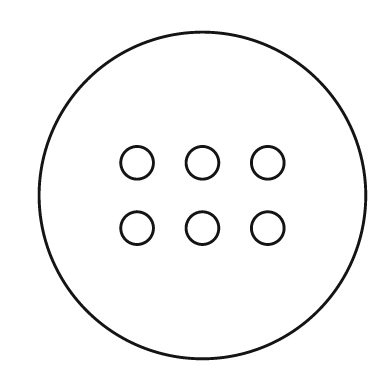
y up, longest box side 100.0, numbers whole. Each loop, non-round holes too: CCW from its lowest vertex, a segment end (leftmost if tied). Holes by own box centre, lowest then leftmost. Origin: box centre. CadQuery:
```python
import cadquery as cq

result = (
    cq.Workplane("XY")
    .moveTo(0.0, 0.0)
    .circle(50.0)
    .moveTo(-20.0, -10.0)
    .circle(5.0)
    .moveTo(0.0, -10.0)
    .circle(5.0)
    .moveTo(20.0, -10.0)
    .circle(5.0)
    .moveTo(-20.0, 10.0)
    .circle(5.0)
    .moveTo(0.0, 10.0)
    .circle(5.0)
    .moveTo(20.0, 10.0)
    .circle(5.0)
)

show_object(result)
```